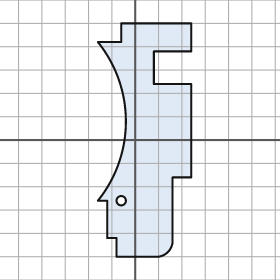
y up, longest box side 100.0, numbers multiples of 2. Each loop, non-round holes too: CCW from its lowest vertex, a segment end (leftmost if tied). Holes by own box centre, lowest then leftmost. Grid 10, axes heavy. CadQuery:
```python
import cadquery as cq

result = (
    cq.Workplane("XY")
    .moveTo(-8.0, -50.0)
    .lineTo(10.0, -50.0)
    .threePointArc((14.0, -48.0), (16.0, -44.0))
    .lineTo(16.0, -16.0)
    .lineTo(24.0, -16.0)
    .lineTo(24.0, 24.0)
    .lineTo(8.0, 24.0)
    .lineTo(8.0, 38.0)
    .lineTo(24.0, 38.0)
    .lineTo(24.0, 50.0)
    .lineTo(-6.0, 50.0)
    .lineTo(-6.0, 42.0)
    .lineTo(-16.0, 42.0)
    .threePointArc((-4.0, 8.0), (-16.0, -26.0))
    .lineTo(-12.0, -26.0)
    .lineTo(-12.0, -42.0)
    .lineTo(-8.0, -42.0)
    .close()
    .moveTo(-6.0, -26.0)
    .circle(2.0)
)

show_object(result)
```